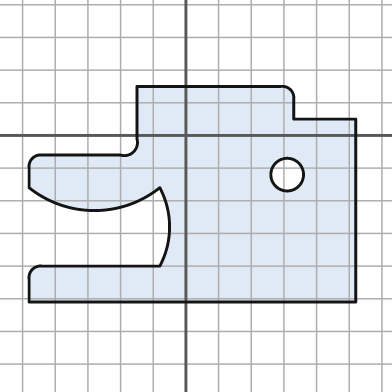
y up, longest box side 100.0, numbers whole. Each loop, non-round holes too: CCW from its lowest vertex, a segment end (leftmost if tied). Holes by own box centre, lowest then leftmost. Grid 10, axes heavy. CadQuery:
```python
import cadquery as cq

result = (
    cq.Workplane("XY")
    .moveTo(-48.0, -51.0)
    .lineTo(52.0, -51.0)
    .lineTo(52.0, 5.0)
    .lineTo(33.0, 5.0)
    .lineTo(33.0, 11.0)
    .threePointArc((32.0, 14.0), (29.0, 15.0))
    .lineTo(-15.0, 15.0)
    .lineTo(-15.0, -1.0)
    .threePointArc((-16.0, -5.0), (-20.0, -6.0))
    .lineTo(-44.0, -6.0)
    .threePointArc((-47.0, -7.0), (-48.0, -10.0))
    .lineTo(-48.0, -16.0)
    .threePointArc((-28.0, -23.0), (-8.0, -16.0))
    .threePointArc((-5.0, -28.0), (-8.0, -40.0))
    .lineTo(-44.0, -40.0)
    .threePointArc((-47.0, -41.0), (-48.0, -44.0))
    .close()
    .moveTo(31.0, -12.0)
    .circle(5.0)
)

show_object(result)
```